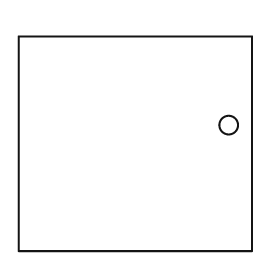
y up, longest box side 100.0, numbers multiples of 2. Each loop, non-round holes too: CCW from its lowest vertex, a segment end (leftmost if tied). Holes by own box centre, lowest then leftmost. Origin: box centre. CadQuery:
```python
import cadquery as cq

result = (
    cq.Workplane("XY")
    .moveTo(-50.0, -46.0)
    .lineTo(50.0, -46.0)
    .lineTo(50.0, 46.0)
    .lineTo(-50.0, 46.0)
    .close()
    .moveTo(40.0, 8.0)
    .circle(4.0)
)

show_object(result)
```